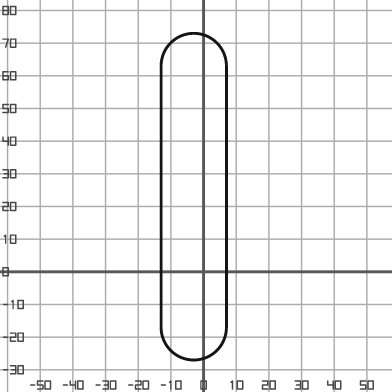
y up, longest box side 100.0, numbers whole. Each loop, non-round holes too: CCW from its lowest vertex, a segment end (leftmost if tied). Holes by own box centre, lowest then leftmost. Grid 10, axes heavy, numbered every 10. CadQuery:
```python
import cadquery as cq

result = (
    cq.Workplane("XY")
    .moveTo(-13.0, -17.0)
    .threePointArc((-3.0, -27.0), (7.0, -17.0))
    .lineTo(7.0, 63.0)
    .threePointArc((-3.0, 73.0), (-13.0, 63.0))
    .close()
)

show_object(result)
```